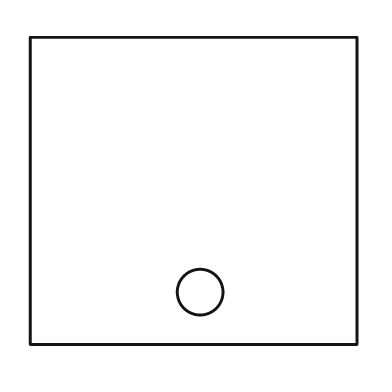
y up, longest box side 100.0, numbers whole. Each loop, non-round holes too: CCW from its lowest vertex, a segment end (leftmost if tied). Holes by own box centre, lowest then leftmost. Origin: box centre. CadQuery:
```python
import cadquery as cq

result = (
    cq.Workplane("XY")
    .moveTo(-50.0, -47.0)
    .lineTo(50.0, -47.0)
    .lineTo(50.0, 47.0)
    .lineTo(-50.0, 47.0)
    .close()
    .moveTo(2.0, -31.0)
    .circle(7.0)
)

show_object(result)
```